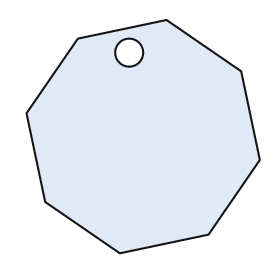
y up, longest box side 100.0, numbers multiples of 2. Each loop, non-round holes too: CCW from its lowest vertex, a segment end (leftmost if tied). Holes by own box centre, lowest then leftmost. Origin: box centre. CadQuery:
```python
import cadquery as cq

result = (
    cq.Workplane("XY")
    .moveTo(-10.0, -50.0)
    .lineTo(28.0, -42.0)
    .lineTo(50.0, -10.0)
    .lineTo(42.0, 28.0)
    .lineTo(10.0, 50.0)
    .lineTo(-28.0, 42.0)
    .lineTo(-50.0, 10.0)
    .lineTo(-42.0, -28.0)
    .close()
    .moveTo(-6.0, 36.0)
    .circle(6.0)
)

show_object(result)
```